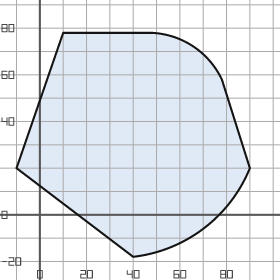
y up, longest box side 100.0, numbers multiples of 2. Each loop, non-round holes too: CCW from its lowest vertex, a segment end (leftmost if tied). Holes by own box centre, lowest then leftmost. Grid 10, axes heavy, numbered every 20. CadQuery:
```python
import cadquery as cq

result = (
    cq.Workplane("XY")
    .moveTo(40.0, -18.0)
    .threePointArc((70.0, -6.0), (90.0, 20.0))
    .lineTo(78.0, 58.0)
    .threePointArc((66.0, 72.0), (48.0, 78.0))
    .lineTo(10.0, 78.0)
    .lineTo(-10.0, 20.0)
    .close()
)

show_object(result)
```